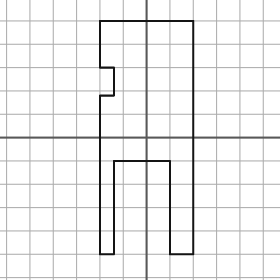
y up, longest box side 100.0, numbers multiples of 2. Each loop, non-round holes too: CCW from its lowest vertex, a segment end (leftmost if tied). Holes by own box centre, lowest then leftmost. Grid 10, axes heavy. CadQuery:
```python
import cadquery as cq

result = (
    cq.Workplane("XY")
    .moveTo(-20.0, -50.0)
    .lineTo(-14.0, -50.0)
    .lineTo(-14.0, -10.0)
    .lineTo(10.0, -10.0)
    .lineTo(10.0, -50.0)
    .lineTo(20.0, -50.0)
    .lineTo(20.0, 50.0)
    .lineTo(-20.0, 50.0)
    .lineTo(-20.0, 30.0)
    .lineTo(-14.0, 30.0)
    .lineTo(-14.0, 18.0)
    .lineTo(-20.0, 18.0)
    .close()
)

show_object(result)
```